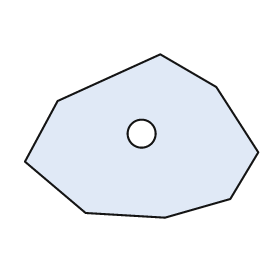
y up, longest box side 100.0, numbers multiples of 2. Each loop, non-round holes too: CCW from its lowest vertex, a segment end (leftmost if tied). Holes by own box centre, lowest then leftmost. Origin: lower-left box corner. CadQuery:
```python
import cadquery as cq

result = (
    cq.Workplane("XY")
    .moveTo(60.0, 0.0)
    .lineTo(88.0, 8.0)
    .lineTo(100.0, 28.0)
    .lineTo(82.0, 56.0)
    .lineTo(58.0, 70.0)
    .lineTo(14.0, 50.0)
    .lineTo(0.0, 24.0)
    .lineTo(26.0, 2.0)
    .close()
    .moveTo(50.0, 36.0)
    .circle(6.0)
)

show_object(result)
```